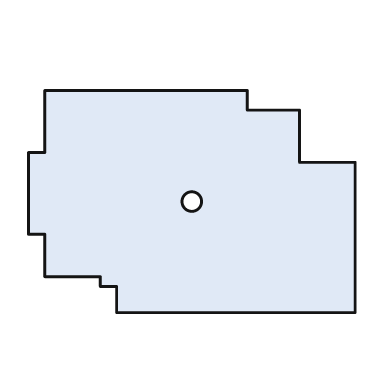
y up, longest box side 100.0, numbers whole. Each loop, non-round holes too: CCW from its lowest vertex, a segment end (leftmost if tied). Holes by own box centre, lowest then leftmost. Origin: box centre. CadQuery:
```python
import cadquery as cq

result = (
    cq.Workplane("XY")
    .moveTo(-23.0, -34.0)
    .lineTo(50.0, -34.0)
    .lineTo(50.0, 12.0)
    .lineTo(33.0, 12.0)
    .lineTo(33.0, 28.0)
    .lineTo(17.0, 28.0)
    .lineTo(17.0, 34.0)
    .lineTo(-45.0, 34.0)
    .lineTo(-45.0, 15.0)
    .lineTo(-50.0, 15.0)
    .lineTo(-50.0, -10.0)
    .lineTo(-45.0, -10.0)
    .lineTo(-45.0, -23.0)
    .lineTo(-28.0, -23.0)
    .lineTo(-28.0, -26.0)
    .lineTo(-23.0, -26.0)
    .close()
    .moveTo(0.0, 0.0)
    .circle(3.0)
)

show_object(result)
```